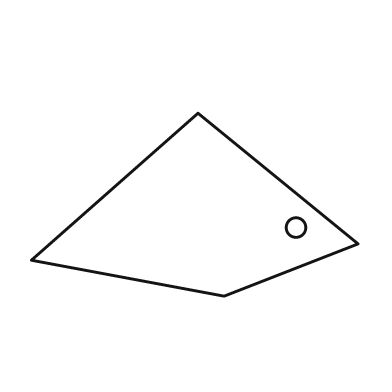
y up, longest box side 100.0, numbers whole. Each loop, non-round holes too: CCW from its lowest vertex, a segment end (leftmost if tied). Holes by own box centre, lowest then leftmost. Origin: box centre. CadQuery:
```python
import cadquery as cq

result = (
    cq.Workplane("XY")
    .moveTo(9.0, -28.0)
    .lineTo(50.0, -12.0)
    .lineTo(1.0, 28.0)
    .lineTo(-50.0, -17.0)
    .close()
    .moveTo(31.0, -7.0)
    .circle(3.0)
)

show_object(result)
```